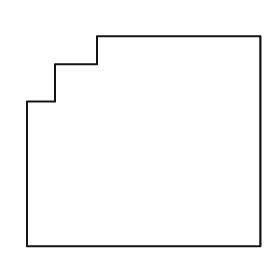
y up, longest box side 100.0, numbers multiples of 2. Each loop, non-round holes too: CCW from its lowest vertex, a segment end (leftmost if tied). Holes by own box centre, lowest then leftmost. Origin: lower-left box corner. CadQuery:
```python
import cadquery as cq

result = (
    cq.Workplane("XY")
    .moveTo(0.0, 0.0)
    .lineTo(100.0, 0.0)
    .lineTo(100.0, 90.0)
    .lineTo(30.0, 90.0)
    .lineTo(30.0, 78.0)
    .lineTo(12.0, 78.0)
    .lineTo(12.0, 62.0)
    .lineTo(0.0, 62.0)
    .close()
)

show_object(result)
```